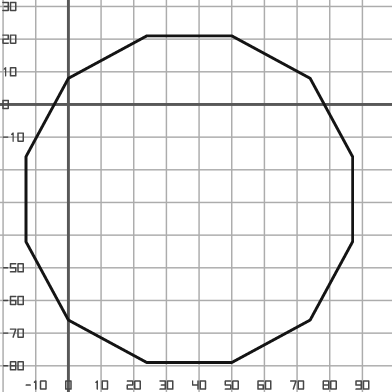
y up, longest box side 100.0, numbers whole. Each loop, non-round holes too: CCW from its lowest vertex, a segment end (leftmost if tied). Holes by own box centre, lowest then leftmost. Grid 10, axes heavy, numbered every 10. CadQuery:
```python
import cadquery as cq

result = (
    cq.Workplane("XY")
    .moveTo(24.0, -79.0)
    .lineTo(50.0, -79.0)
    .lineTo(74.0, -66.0)
    .lineTo(87.0, -42.0)
    .lineTo(87.0, -16.0)
    .lineTo(74.0, 8.0)
    .lineTo(50.0, 21.0)
    .lineTo(24.0, 21.0)
    .lineTo(0.0, 8.0)
    .lineTo(-13.0, -16.0)
    .lineTo(-13.0, -42.0)
    .lineTo(0.0, -66.0)
    .close()
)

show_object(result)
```